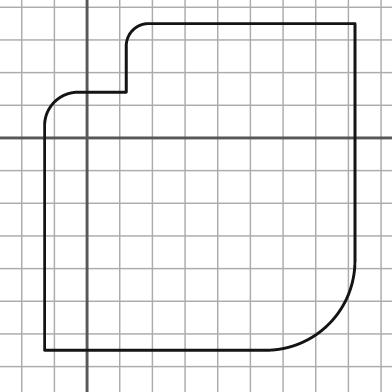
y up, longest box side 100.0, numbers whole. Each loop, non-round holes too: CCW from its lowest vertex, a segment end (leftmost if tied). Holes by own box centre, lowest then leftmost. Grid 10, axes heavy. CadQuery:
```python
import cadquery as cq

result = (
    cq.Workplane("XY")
    .moveTo(-13.0, -65.0)
    .lineTo(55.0, -65.0)
    .threePointArc((74.0, -57.0), (82.0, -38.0))
    .lineTo(82.0, 35.0)
    .lineTo(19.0, 35.0)
    .threePointArc((14.0, 33.0), (12.0, 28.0))
    .lineTo(12.0, 14.0)
    .lineTo(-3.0, 14.0)
    .threePointArc((-10.0, 11.0), (-13.0, 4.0))
    .close()
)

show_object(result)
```